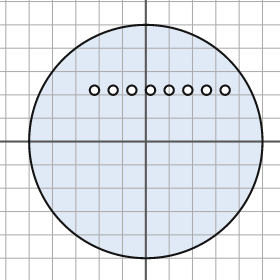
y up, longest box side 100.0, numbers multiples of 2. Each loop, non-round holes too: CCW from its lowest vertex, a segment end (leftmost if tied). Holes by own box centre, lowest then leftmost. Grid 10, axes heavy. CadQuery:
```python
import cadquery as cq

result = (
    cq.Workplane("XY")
    .moveTo(0.0, 0.0)
    .circle(50.0)
    .moveTo(-22.0, 22.0)
    .circle(2.0)
    .moveTo(-14.0, 22.0)
    .circle(2.0)
    .moveTo(-6.0, 22.0)
    .circle(2.0)
    .moveTo(2.0, 22.0)
    .circle(2.0)
    .moveTo(10.0, 22.0)
    .circle(2.0)
    .moveTo(18.0, 22.0)
    .circle(2.0)
    .moveTo(26.0, 22.0)
    .circle(2.0)
    .moveTo(34.0, 22.0)
    .circle(2.0)
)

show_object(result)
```